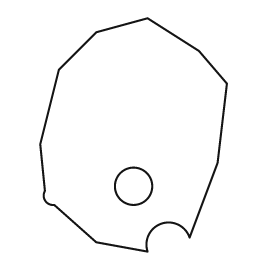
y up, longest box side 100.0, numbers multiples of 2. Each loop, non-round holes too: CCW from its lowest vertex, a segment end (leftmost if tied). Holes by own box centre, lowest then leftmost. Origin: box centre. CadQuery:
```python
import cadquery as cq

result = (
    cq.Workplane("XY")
    .moveTo(6.0, -50.0)
    .threePointArc((12.0, -38.0), (24.0, -44.0))
    .lineTo(36.0, -12.0)
    .lineTo(40.0, 22.0)
    .lineTo(28.0, 36.0)
    .lineTo(6.0, 50.0)
    .lineTo(-16.0, 44.0)
    .lineTo(-32.0, 28.0)
    .lineTo(-40.0, -4.0)
    .lineTo(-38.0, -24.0)
    .threePointArc((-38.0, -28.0), (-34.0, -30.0))
    .lineTo(-16.0, -46.0)
    .close()
    .moveTo(0.0, -22.0)
    .circle(8.0)
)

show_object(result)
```